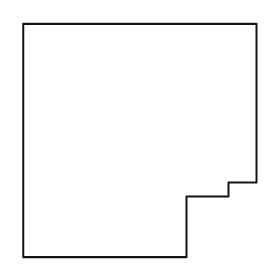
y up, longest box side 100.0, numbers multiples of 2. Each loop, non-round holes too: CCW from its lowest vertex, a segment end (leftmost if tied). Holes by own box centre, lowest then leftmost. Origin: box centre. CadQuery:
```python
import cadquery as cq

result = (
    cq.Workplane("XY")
    .moveTo(-50.0, -50.0)
    .lineTo(20.0, -50.0)
    .lineTo(20.0, -24.0)
    .lineTo(38.0, -24.0)
    .lineTo(38.0, -18.0)
    .lineTo(50.0, -18.0)
    .lineTo(50.0, 50.0)
    .lineTo(-50.0, 50.0)
    .close()
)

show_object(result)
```